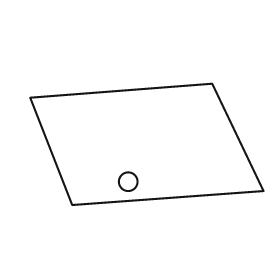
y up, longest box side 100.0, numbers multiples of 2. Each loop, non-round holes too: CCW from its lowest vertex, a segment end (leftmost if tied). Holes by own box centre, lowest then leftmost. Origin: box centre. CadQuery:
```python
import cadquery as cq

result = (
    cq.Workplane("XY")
    .moveTo(-32.0, -26.0)
    .lineTo(50.0, -20.0)
    .lineTo(28.0, 26.0)
    .lineTo(-50.0, 20.0)
    .close()
    .moveTo(-8.0, -16.0)
    .circle(4.0)
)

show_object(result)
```